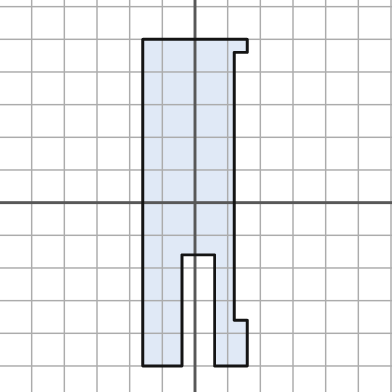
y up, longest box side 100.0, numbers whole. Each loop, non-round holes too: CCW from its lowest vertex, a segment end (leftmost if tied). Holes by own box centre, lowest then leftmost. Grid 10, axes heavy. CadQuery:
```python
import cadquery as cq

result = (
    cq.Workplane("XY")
    .moveTo(-16.0, -50.0)
    .lineTo(-4.0, -50.0)
    .lineTo(-4.0, -16.0)
    .lineTo(6.0, -16.0)
    .lineTo(6.0, -50.0)
    .lineTo(16.0, -50.0)
    .lineTo(16.0, -36.0)
    .lineTo(12.0, -36.0)
    .lineTo(12.0, 46.0)
    .lineTo(16.0, 46.0)
    .lineTo(16.0, 50.0)
    .lineTo(-16.0, 50.0)
    .close()
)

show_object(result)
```